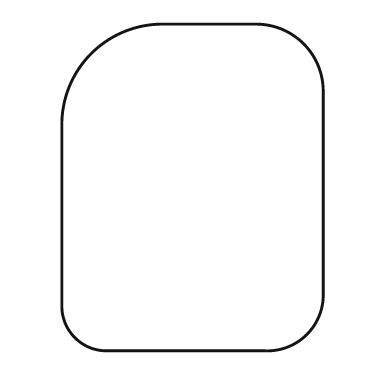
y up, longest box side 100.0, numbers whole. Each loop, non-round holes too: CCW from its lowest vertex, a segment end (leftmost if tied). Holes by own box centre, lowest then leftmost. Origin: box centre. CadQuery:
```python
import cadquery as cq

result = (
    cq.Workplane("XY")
    .moveTo(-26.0, -50.0)
    .lineTo(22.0, -50.0)
    .threePointArc((35.0, -45.0), (40.0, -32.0))
    .lineTo(40.0, 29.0)
    .threePointArc((34.0, 44.0), (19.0, 50.0))
    .lineTo(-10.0, 50.0)
    .threePointArc((-31.0, 41.0), (-40.0, 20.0))
    .lineTo(-40.0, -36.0)
    .threePointArc((-36.0, -46.0), (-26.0, -50.0))
    .close()
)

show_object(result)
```